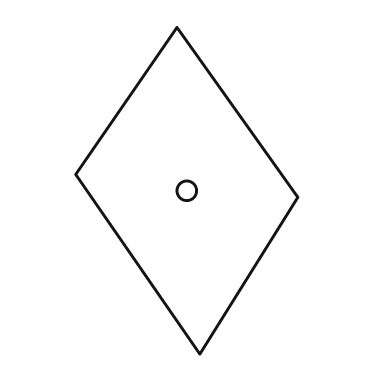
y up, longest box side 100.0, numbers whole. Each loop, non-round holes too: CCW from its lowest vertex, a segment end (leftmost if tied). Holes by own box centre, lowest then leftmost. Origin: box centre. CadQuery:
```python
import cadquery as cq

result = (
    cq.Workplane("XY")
    .moveTo(4.0, -50.0)
    .lineTo(34.0, -2.0)
    .lineTo(-3.0, 50.0)
    .lineTo(-34.0, 5.0)
    .close()
    .moveTo(0.0, 0.0)
    .circle(3.0)
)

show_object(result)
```